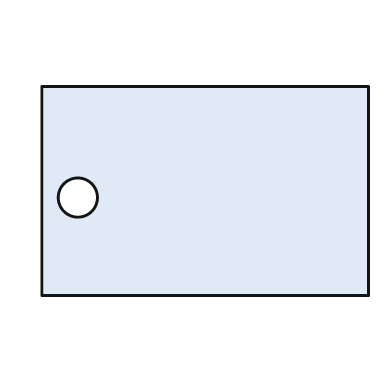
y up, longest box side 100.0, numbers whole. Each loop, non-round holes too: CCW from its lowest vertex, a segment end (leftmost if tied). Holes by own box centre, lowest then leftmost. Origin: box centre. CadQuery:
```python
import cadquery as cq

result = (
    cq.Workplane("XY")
    .moveTo(-50.0, -32.0)
    .lineTo(50.0, -32.0)
    .lineTo(50.0, 32.0)
    .lineTo(-50.0, 32.0)
    .close()
    .moveTo(-39.0, -2.0)
    .circle(6.0)
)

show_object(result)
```